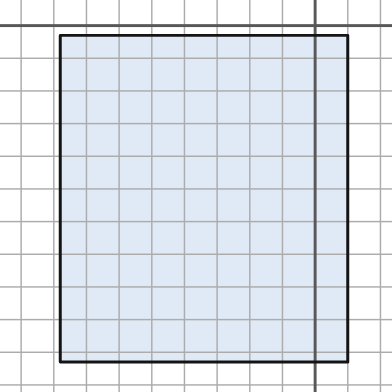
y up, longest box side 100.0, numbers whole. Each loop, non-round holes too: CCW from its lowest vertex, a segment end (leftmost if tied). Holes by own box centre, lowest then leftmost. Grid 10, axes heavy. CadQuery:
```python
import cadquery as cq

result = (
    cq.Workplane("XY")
    .moveTo(-78.0, -103.0)
    .lineTo(10.0, -103.0)
    .lineTo(10.0, -3.0)
    .lineTo(-78.0, -3.0)
    .close()
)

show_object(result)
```